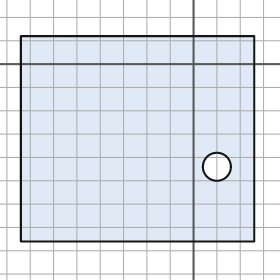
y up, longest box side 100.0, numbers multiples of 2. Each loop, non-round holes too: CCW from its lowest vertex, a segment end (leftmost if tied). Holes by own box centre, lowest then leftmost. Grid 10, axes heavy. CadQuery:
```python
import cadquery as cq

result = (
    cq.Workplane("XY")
    .moveTo(-74.0, -76.0)
    .lineTo(26.0, -76.0)
    .lineTo(26.0, 12.0)
    .lineTo(-74.0, 12.0)
    .close()
    .moveTo(10.0, -44.0)
    .circle(6.0)
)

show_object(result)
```